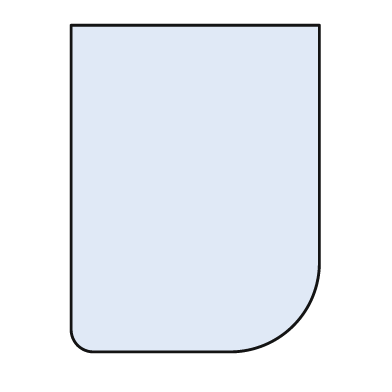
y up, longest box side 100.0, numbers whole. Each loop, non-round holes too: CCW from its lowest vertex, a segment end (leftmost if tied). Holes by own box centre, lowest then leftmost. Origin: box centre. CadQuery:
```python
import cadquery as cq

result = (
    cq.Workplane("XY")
    .moveTo(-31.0, -50.0)
    .lineTo(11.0, -50.0)
    .threePointArc((30.0, -42.0), (38.0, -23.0))
    .lineTo(38.0, 50.0)
    .lineTo(-38.0, 50.0)
    .lineTo(-38.0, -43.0)
    .threePointArc((-36.0, -48.0), (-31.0, -50.0))
    .close()
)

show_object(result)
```